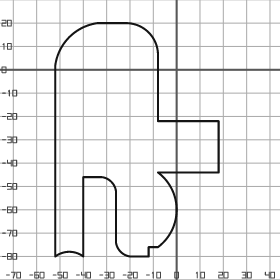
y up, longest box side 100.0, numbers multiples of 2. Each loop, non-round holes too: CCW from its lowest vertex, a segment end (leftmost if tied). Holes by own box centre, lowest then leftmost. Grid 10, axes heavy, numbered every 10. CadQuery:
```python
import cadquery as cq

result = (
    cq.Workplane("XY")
    .moveTo(-52.0, -80.0)
    .threePointArc((-46.0, -78.0), (-40.0, -80.0))
    .lineTo(-40.0, -46.0)
    .lineTo(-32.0, -46.0)
    .threePointArc((-28.0, -48.0), (-26.0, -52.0))
    .lineTo(-26.0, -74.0)
    .threePointArc((-24.0, -78.0), (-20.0, -80.0))
    .lineTo(-12.0, -80.0)
    .lineTo(-12.0, -76.0)
    .lineTo(-8.0, -76.0)
    .threePointArc((0.0, -60.0), (-8.0, -44.0))
    .lineTo(18.0, -44.0)
    .lineTo(18.0, -22.0)
    .lineTo(-8.0, -22.0)
    .lineTo(-8.0, 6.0)
    .threePointArc((-12.0, 16.0), (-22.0, 20.0))
    .lineTo(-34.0, 20.0)
    .threePointArc((-46.0, 14.0), (-52.0, 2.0))
    .close()
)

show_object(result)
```